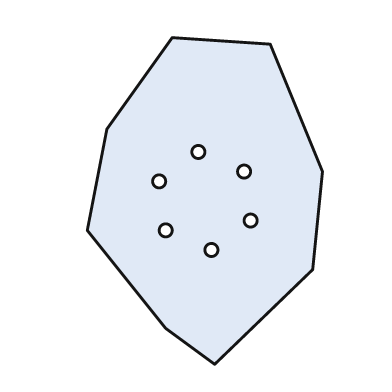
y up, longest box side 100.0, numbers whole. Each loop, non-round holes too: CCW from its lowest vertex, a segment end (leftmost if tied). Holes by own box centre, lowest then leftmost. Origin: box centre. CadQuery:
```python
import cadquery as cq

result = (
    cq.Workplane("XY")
    .moveTo(3.0, -50.0)
    .lineTo(33.0, -21.0)
    .lineTo(36.0, 9.0)
    .lineTo(20.0, 48.0)
    .lineTo(-10.0, 50.0)
    .lineTo(-30.0, 22.0)
    .lineTo(-36.0, -9.0)
    .lineTo(-12.0, -39.0)
    .close()
    .moveTo(2.0, -15.0)
    .circle(2.0)
    .moveTo(-12.0, -9.0)
    .circle(2.0)
    .moveTo(14.0, -6.0)
    .circle(2.0)
    .moveTo(-14.0, 6.0)
    .circle(2.0)
    .moveTo(12.0, 9.0)
    .circle(2.0)
    .moveTo(-2.0, 15.0)
    .circle(2.0)
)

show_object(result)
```